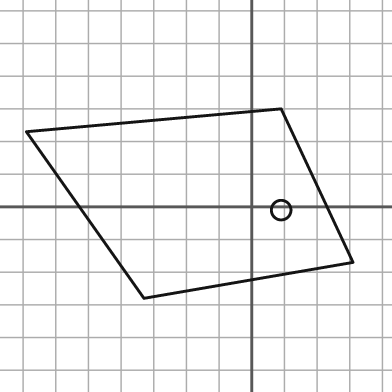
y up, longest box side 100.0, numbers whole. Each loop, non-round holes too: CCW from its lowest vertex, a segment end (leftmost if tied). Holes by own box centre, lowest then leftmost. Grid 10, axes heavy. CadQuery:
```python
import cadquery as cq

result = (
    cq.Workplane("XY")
    .moveTo(-33.0, -28.0)
    .lineTo(31.0, -17.0)
    .lineTo(9.0, 30.0)
    .lineTo(-69.0, 23.0)
    .close()
    .moveTo(9.0, -1.0)
    .circle(3.0)
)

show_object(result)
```